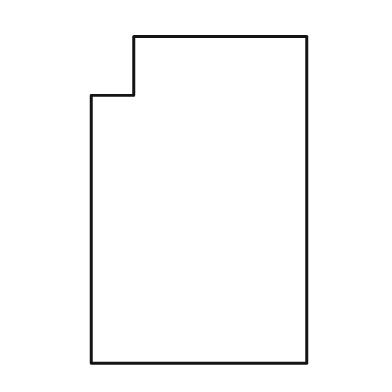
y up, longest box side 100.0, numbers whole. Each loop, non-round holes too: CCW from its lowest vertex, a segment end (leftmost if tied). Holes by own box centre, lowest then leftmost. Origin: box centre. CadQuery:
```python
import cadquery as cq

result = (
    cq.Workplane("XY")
    .moveTo(-33.0, -50.0)
    .lineTo(33.0, -50.0)
    .lineTo(33.0, 50.0)
    .lineTo(-20.0, 50.0)
    .lineTo(-20.0, 32.0)
    .lineTo(-33.0, 32.0)
    .close()
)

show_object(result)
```